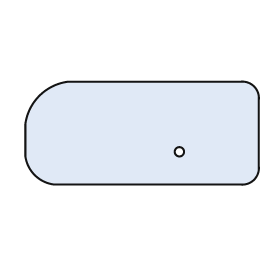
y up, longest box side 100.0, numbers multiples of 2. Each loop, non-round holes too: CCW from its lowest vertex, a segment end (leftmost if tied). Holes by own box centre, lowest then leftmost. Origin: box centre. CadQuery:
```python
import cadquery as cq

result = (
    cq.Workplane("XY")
    .moveTo(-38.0, -22.0)
    .lineTo(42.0, -22.0)
    .threePointArc((48.0, -20.0), (50.0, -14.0))
    .lineTo(50.0, 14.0)
    .threePointArc((48.0, 20.0), (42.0, 22.0))
    .lineTo(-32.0, 22.0)
    .threePointArc((-44.0, 16.0), (-50.0, 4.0))
    .lineTo(-50.0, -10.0)
    .threePointArc((-46.0, -18.0), (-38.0, -22.0))
    .close()
    .moveTo(16.0, -8.0)
    .circle(2.0)
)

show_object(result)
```